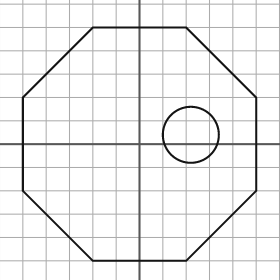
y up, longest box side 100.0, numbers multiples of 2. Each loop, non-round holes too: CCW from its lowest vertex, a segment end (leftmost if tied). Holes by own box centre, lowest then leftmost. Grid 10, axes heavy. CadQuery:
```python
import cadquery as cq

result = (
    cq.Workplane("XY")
    .moveTo(-20.0, -50.0)
    .lineTo(20.0, -50.0)
    .lineTo(50.0, -20.0)
    .lineTo(50.0, 20.0)
    .lineTo(20.0, 50.0)
    .lineTo(-20.0, 50.0)
    .lineTo(-50.0, 20.0)
    .lineTo(-50.0, -20.0)
    .close()
    .moveTo(22.0, 4.0)
    .circle(12.0)
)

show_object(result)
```